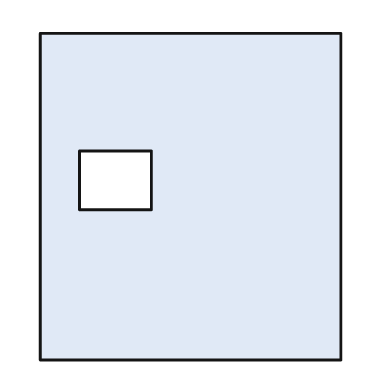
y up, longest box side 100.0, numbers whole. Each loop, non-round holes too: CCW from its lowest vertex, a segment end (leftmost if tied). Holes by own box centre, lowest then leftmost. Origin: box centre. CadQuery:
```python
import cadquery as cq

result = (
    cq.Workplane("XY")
    .moveTo(-46.0, -50.0)
    .lineTo(46.0, -50.0)
    .lineTo(46.0, 50.0)
    .lineTo(-46.0, 50.0)
    .close()
    .moveTo(-34.0, -4.0)
    .lineTo(-12.0, -4.0)
    .lineTo(-12.0, 14.0)
    .lineTo(-34.0, 14.0)
    .close()
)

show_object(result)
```